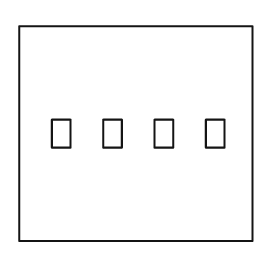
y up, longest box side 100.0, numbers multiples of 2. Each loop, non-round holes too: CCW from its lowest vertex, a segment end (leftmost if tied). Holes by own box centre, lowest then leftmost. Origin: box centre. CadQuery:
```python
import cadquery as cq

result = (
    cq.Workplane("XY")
    .moveTo(-50.0, -46.0)
    .lineTo(50.0, -46.0)
    .lineTo(50.0, 46.0)
    .lineTo(-50.0, 46.0)
    .close()
    .moveTo(-36.0, -6.0)
    .lineTo(-28.0, -6.0)
    .lineTo(-28.0, 6.0)
    .lineTo(-36.0, 6.0)
    .close()
    .moveTo(-14.0, -6.0)
    .lineTo(-6.0, -6.0)
    .lineTo(-6.0, 6.0)
    .lineTo(-14.0, 6.0)
    .close()
    .moveTo(8.0, -6.0)
    .lineTo(16.0, -6.0)
    .lineTo(16.0, 6.0)
    .lineTo(8.0, 6.0)
    .close()
    .moveTo(30.0, -6.0)
    .lineTo(38.0, -6.0)
    .lineTo(38.0, 6.0)
    .lineTo(30.0, 6.0)
    .close()
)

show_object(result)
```